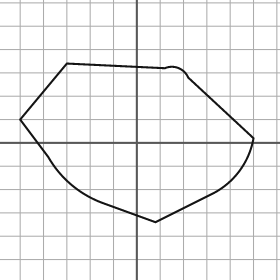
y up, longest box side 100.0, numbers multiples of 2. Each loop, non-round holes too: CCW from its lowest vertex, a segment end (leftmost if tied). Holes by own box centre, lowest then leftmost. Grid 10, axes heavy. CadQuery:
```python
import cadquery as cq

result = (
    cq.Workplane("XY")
    .moveTo(8.0, -34.0)
    .lineTo(32.0, -22.0)
    .threePointArc((44.0, -12.0), (50.0, 2.0))
    .lineTo(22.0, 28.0)
    .threePointArc((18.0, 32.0), (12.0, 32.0))
    .lineTo(-30.0, 34.0)
    .lineTo(-50.0, 10.0)
    .lineTo(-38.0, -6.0)
    .threePointArc((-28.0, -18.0), (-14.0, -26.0))
    .close()
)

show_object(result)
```